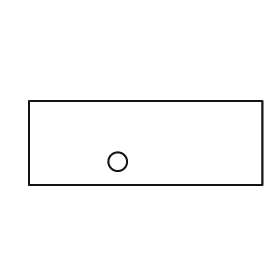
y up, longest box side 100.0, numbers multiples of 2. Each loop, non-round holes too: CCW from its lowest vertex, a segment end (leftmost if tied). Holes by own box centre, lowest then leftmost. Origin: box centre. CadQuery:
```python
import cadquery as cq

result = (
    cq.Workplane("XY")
    .moveTo(-50.0, -18.0)
    .lineTo(50.0, -18.0)
    .lineTo(50.0, 18.0)
    .lineTo(-50.0, 18.0)
    .close()
    .moveTo(-12.0, -8.0)
    .circle(4.0)
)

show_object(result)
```